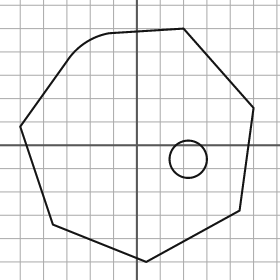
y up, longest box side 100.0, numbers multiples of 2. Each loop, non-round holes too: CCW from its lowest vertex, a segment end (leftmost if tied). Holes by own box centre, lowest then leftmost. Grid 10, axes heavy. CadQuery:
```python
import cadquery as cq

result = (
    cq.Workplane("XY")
    .moveTo(4.0, -50.0)
    .lineTo(44.0, -28.0)
    .lineTo(50.0, 16.0)
    .lineTo(20.0, 50.0)
    .lineTo(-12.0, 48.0)
    .threePointArc((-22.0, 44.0), (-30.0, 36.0))
    .lineTo(-50.0, 8.0)
    .lineTo(-36.0, -34.0)
    .close()
    .moveTo(22.0, -6.0)
    .circle(8.0)
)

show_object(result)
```